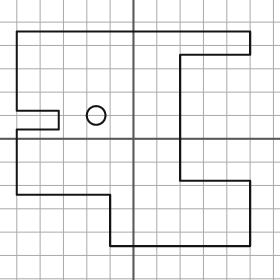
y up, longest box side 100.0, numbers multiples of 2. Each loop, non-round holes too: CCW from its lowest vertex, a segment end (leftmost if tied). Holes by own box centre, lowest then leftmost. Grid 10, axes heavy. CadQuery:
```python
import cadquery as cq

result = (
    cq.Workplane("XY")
    .moveTo(-10.0, -46.0)
    .lineTo(50.0, -46.0)
    .lineTo(50.0, -18.0)
    .lineTo(20.0, -18.0)
    .lineTo(20.0, 36.0)
    .lineTo(50.0, 36.0)
    .lineTo(50.0, 46.0)
    .lineTo(-50.0, 46.0)
    .lineTo(-50.0, 12.0)
    .lineTo(-32.0, 12.0)
    .lineTo(-32.0, 4.0)
    .lineTo(-50.0, 4.0)
    .lineTo(-50.0, -24.0)
    .lineTo(-10.0, -24.0)
    .close()
    .moveTo(-16.0, 10.0)
    .circle(4.0)
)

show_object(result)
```